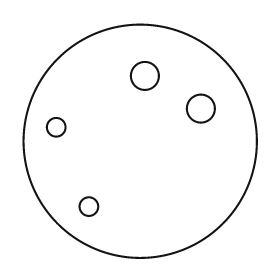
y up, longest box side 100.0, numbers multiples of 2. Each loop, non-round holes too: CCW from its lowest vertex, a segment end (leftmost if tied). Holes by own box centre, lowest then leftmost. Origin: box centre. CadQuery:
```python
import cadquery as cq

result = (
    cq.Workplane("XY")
    .moveTo(0.0, 0.0)
    .circle(50.0)
    .moveTo(-22.0, -28.0)
    .circle(4.0)
    .moveTo(-36.0, 6.0)
    .circle(4.0)
    .moveTo(26.0, 14.0)
    .circle(6.0)
    .moveTo(2.0, 28.0)
    .circle(6.0)
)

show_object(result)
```